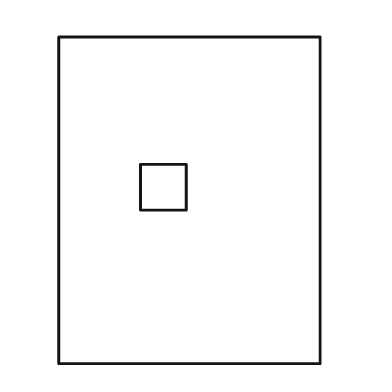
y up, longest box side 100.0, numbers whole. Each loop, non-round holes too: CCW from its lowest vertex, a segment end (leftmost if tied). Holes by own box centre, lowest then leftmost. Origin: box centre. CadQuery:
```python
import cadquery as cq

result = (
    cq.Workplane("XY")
    .moveTo(-40.0, -50.0)
    .lineTo(40.0, -50.0)
    .lineTo(40.0, 50.0)
    .lineTo(-40.0, 50.0)
    .close()
    .moveTo(-15.0, -3.0)
    .lineTo(-1.0, -3.0)
    .lineTo(-1.0, 11.0)
    .lineTo(-15.0, 11.0)
    .close()
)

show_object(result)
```